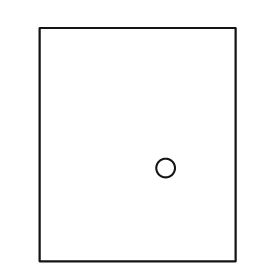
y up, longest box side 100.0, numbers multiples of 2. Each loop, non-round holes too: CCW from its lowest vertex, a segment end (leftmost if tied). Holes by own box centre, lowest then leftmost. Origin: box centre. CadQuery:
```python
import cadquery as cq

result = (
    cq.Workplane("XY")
    .moveTo(-42.0, -50.0)
    .lineTo(42.0, -50.0)
    .lineTo(42.0, 50.0)
    .lineTo(-42.0, 50.0)
    .close()
    .moveTo(12.0, -10.0)
    .circle(4.0)
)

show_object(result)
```